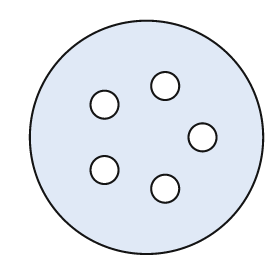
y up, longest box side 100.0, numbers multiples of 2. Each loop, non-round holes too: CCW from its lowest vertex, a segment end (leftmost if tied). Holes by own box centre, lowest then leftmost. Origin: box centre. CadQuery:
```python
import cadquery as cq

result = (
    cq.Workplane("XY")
    .moveTo(0.0, 0.0)
    .circle(50.0)
    .moveTo(8.0, -22.0)
    .circle(6.0)
    .moveTo(-18.0, -14.0)
    .circle(6.0)
    .moveTo(24.0, 0.0)
    .circle(6.0)
    .moveTo(-18.0, 14.0)
    .circle(6.0)
    .moveTo(8.0, 22.0)
    .circle(6.0)
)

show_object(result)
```